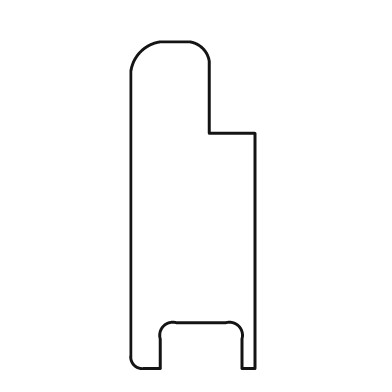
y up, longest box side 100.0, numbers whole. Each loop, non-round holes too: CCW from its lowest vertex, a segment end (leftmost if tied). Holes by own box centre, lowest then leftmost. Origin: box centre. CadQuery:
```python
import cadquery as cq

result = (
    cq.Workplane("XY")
    .moveTo(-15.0, -50.0)
    .lineTo(-10.0, -50.0)
    .lineTo(-10.0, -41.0)
    .threePointArc((-9.0, -37.0), (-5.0, -36.0))
    .lineTo(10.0, -36.0)
    .threePointArc((14.0, -37.0), (15.0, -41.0))
    .lineTo(15.0, -50.0)
    .lineTo(19.0, -50.0)
    .lineTo(19.0, 22.0)
    .lineTo(5.0, 22.0)
    .lineTo(5.0, 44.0)
    .threePointArc((3.0, 48.0), (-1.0, 50.0))
    .lineTo(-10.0, 50.0)
    .threePointArc((-16.0, 47.0), (-19.0, 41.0))
    .lineTo(-19.0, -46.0)
    .threePointArc((-18.0, -49.0), (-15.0, -50.0))
    .close()
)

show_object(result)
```